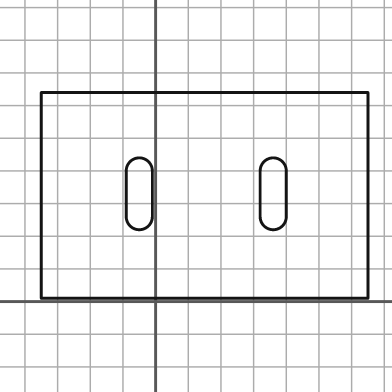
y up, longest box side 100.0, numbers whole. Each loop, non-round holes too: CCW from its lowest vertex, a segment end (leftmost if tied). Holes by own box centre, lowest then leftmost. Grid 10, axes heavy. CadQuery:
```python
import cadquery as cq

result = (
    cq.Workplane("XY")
    .moveTo(-35.0, 1.0)
    .lineTo(65.0, 1.0)
    .lineTo(65.0, 64.0)
    .lineTo(-35.0, 64.0)
    .close()
    .moveTo(-9.0, 26.0)
    .threePointArc((-5.0, 22.0), (-1.0, 26.0))
    .lineTo(-1.0, 40.0)
    .threePointArc((-5.0, 44.0), (-9.0, 40.0))
    .close()
    .moveTo(32.0, 26.0)
    .threePointArc((36.0, 22.0), (40.0, 26.0))
    .lineTo(40.0, 40.0)
    .threePointArc((36.0, 44.0), (32.0, 40.0))
    .close()
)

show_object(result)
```